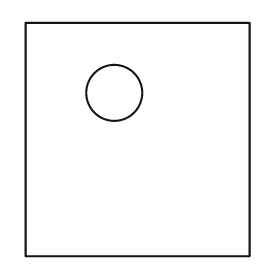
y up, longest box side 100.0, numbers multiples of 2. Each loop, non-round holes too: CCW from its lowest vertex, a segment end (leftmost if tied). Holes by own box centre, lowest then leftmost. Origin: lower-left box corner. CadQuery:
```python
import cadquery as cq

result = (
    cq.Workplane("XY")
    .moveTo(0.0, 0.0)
    .lineTo(96.0, 0.0)
    .lineTo(96.0, 100.0)
    .lineTo(0.0, 100.0)
    .close()
    .moveTo(38.0, 70.0)
    .circle(12.0)
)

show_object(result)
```